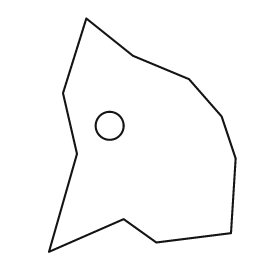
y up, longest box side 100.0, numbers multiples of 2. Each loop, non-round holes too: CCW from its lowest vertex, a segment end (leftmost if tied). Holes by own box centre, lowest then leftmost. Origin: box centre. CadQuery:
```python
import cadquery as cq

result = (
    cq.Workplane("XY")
    .moveTo(-40.0, -50.0)
    .lineTo(-8.0, -36.0)
    .lineTo(6.0, -46.0)
    .lineTo(38.0, -42.0)
    .lineTo(40.0, -10.0)
    .lineTo(34.0, 8.0)
    .lineTo(20.0, 24.0)
    .lineTo(-4.0, 34.0)
    .lineTo(-24.0, 50.0)
    .lineTo(-34.0, 18.0)
    .lineTo(-28.0, -8.0)
    .close()
    .moveTo(-14.0, 4.0)
    .circle(6.0)
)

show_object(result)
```